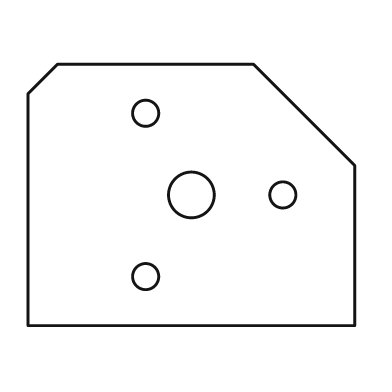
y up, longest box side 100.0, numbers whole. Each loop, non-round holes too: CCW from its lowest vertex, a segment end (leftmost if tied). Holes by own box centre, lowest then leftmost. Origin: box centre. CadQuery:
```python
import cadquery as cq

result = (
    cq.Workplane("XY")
    .moveTo(-50.0, -40.0)
    .lineTo(50.0, -40.0)
    .lineTo(50.0, 9.0)
    .lineTo(19.0, 40.0)
    .lineTo(-41.0, 40.0)
    .lineTo(-50.0, 31.0)
    .close()
    .moveTo(-14.0, -25.0)
    .circle(4.0)
    .moveTo(0.0, 0.0)
    .circle(7.0)
    .moveTo(28.0, 0.0)
    .circle(4.0)
    .moveTo(-14.0, 25.0)
    .circle(4.0)
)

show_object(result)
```